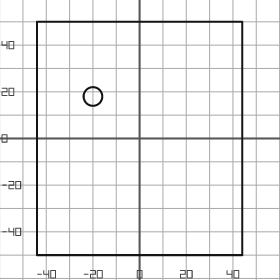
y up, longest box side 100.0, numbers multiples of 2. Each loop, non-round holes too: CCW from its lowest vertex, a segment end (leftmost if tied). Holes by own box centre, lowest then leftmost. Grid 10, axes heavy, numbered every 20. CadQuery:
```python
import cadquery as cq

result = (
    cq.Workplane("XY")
    .moveTo(-44.0, -50.0)
    .lineTo(44.0, -50.0)
    .lineTo(44.0, 50.0)
    .lineTo(-44.0, 50.0)
    .close()
    .moveTo(-20.0, 18.0)
    .circle(4.0)
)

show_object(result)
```